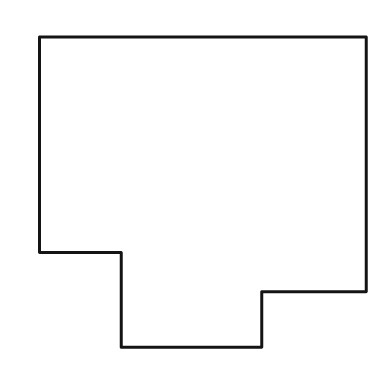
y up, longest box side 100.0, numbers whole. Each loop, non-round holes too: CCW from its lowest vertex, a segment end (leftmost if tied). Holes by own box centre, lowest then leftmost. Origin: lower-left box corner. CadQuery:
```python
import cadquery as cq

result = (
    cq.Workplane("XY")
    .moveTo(25.0, 0.0)
    .lineTo(68.0, 0.0)
    .lineTo(68.0, 17.0)
    .lineTo(100.0, 17.0)
    .lineTo(100.0, 95.0)
    .lineTo(0.0, 95.0)
    .lineTo(0.0, 29.0)
    .lineTo(25.0, 29.0)
    .close()
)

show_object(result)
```